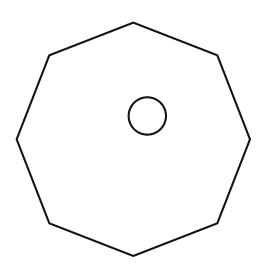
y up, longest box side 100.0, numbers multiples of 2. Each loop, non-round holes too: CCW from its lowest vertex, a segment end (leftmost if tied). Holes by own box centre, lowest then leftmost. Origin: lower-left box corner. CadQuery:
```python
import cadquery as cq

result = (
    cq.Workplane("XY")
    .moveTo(50.0, 0.0)
    .lineTo(86.0, 14.0)
    .lineTo(100.0, 50.0)
    .lineTo(86.0, 86.0)
    .lineTo(50.0, 100.0)
    .lineTo(14.0, 86.0)
    .lineTo(0.0, 50.0)
    .lineTo(14.0, 14.0)
    .close()
    .moveTo(56.0, 60.0)
    .circle(8.0)
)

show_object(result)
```